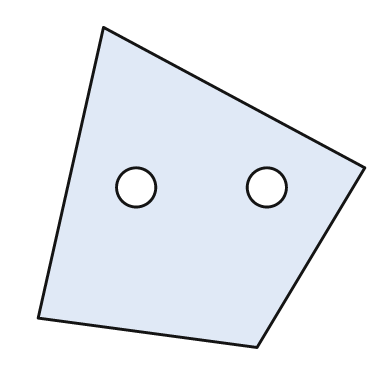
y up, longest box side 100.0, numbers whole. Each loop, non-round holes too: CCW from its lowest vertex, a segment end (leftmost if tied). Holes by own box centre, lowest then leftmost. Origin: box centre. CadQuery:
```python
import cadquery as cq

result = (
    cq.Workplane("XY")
    .moveTo(17.0, -49.0)
    .lineTo(50.0, 6.0)
    .lineTo(-30.0, 49.0)
    .lineTo(-50.0, -40.0)
    .close()
    .moveTo(-20.0, 0.0)
    .circle(6.0)
    .moveTo(20.0, 0.0)
    .circle(6.0)
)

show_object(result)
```